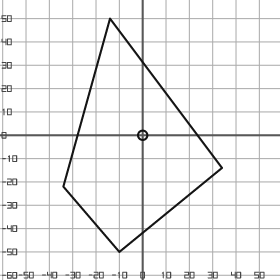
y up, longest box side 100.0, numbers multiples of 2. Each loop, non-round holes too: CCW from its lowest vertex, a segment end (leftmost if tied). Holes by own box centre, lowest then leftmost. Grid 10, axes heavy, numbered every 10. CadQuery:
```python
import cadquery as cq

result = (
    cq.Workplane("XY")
    .moveTo(-10.0, -50.0)
    .lineTo(34.0, -14.0)
    .lineTo(-14.0, 50.0)
    .lineTo(-34.0, -22.0)
    .close()
    .moveTo(0.0, 0.0)
    .circle(2.0)
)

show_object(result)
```